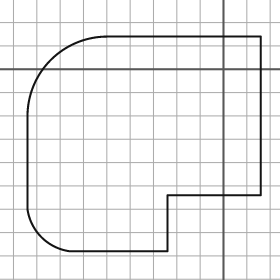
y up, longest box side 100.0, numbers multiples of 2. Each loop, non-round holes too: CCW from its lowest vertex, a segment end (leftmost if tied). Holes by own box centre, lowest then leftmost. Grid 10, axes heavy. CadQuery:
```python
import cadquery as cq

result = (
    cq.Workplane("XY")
    .moveTo(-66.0, -78.0)
    .lineTo(-24.0, -78.0)
    .lineTo(-24.0, -54.0)
    .lineTo(16.0, -54.0)
    .lineTo(16.0, 14.0)
    .lineTo(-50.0, 14.0)
    .threePointArc((-74.0, 4.0), (-84.0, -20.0))
    .lineTo(-84.0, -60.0)
    .threePointArc((-78.0, -72.0), (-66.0, -78.0))
    .close()
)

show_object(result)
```